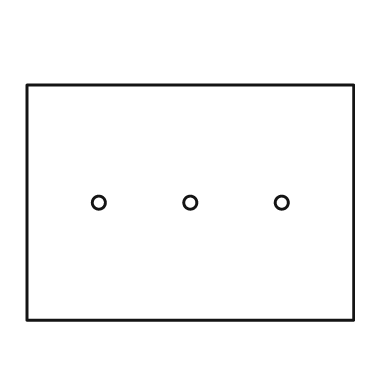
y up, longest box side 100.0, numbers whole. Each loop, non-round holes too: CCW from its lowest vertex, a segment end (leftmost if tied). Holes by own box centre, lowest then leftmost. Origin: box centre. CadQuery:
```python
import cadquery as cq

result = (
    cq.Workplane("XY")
    .moveTo(-50.0, -36.0)
    .lineTo(50.0, -36.0)
    .lineTo(50.0, 36.0)
    .lineTo(-50.0, 36.0)
    .close()
    .moveTo(-28.0, 0.0)
    .circle(2.0)
    .moveTo(0.0, 0.0)
    .circle(2.0)
    .moveTo(28.0, 0.0)
    .circle(2.0)
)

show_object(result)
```